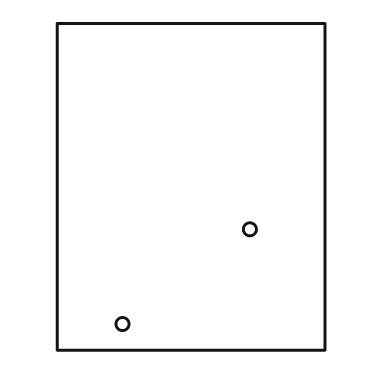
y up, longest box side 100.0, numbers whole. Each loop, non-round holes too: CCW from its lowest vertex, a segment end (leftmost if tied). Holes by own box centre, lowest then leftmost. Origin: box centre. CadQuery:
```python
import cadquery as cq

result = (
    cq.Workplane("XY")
    .moveTo(-41.0, -50.0)
    .lineTo(41.0, -50.0)
    .lineTo(41.0, 50.0)
    .lineTo(-41.0, 50.0)
    .close()
    .moveTo(-21.0, -42.0)
    .circle(2.0)
    .moveTo(18.0, -13.0)
    .circle(2.0)
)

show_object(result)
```